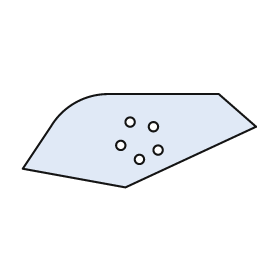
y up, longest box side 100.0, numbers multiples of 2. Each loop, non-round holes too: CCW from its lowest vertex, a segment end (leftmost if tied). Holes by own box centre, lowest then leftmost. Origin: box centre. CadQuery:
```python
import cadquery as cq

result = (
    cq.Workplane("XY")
    .moveTo(-6.0, -20.0)
    .lineTo(50.0, 6.0)
    .lineTo(34.0, 20.0)
    .lineTo(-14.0, 20.0)
    .threePointArc((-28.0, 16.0), (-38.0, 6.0))
    .lineTo(-50.0, -12.0)
    .close()
    .moveTo(0.0, -8.0)
    .circle(2.0)
    .moveTo(8.0, -4.0)
    .circle(2.0)
    .moveTo(-8.0, -2.0)
    .circle(2.0)
    .moveTo(6.0, 6.0)
    .circle(2.0)
    .moveTo(-4.0, 8.0)
    .circle(2.0)
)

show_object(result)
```